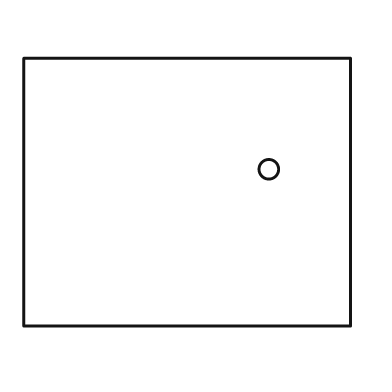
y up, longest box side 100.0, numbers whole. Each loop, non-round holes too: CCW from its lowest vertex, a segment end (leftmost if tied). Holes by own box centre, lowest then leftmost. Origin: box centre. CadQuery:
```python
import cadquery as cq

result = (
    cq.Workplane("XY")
    .moveTo(-50.0, -41.0)
    .lineTo(50.0, -41.0)
    .lineTo(50.0, 41.0)
    .lineTo(-50.0, 41.0)
    .close()
    .moveTo(25.0, 7.0)
    .circle(3.0)
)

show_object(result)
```